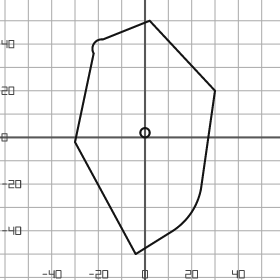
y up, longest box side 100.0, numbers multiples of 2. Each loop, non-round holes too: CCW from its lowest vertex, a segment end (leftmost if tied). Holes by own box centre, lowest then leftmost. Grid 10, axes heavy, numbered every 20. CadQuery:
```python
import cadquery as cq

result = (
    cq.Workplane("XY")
    .moveTo(-4.0, -50.0)
    .lineTo(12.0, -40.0)
    .threePointArc((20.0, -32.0), (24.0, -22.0))
    .lineTo(30.0, 20.0)
    .lineTo(2.0, 50.0)
    .lineTo(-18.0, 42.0)
    .threePointArc((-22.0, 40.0), (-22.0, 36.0))
    .lineTo(-30.0, -2.0)
    .close()
    .moveTo(0.0, 2.0)
    .circle(2.0)
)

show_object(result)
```